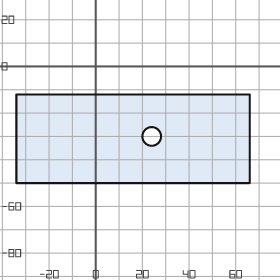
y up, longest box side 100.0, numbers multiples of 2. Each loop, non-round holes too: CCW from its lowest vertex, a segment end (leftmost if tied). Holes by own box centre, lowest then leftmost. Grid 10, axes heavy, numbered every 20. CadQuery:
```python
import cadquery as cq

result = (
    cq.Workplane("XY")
    .moveTo(-34.0, -50.0)
    .lineTo(66.0, -50.0)
    .lineTo(66.0, -12.0)
    .lineTo(-34.0, -12.0)
    .close()
    .moveTo(24.0, -30.0)
    .circle(4.0)
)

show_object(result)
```